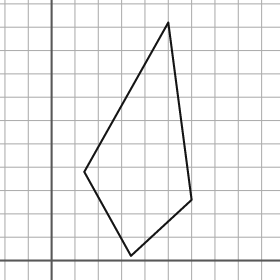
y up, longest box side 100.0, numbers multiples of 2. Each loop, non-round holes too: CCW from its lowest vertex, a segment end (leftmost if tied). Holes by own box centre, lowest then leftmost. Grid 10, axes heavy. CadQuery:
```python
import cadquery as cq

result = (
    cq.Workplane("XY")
    .moveTo(34.0, 2.0)
    .lineTo(60.0, 26.0)
    .lineTo(50.0, 102.0)
    .lineTo(14.0, 38.0)
    .close()
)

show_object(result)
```